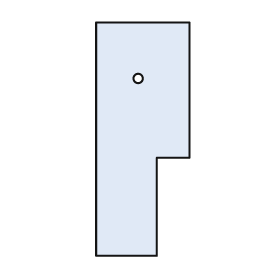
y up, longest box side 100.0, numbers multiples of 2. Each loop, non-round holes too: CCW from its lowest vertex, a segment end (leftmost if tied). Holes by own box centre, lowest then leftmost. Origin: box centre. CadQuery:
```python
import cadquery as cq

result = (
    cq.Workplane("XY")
    .moveTo(-20.0, -50.0)
    .lineTo(6.0, -50.0)
    .lineTo(6.0, -8.0)
    .lineTo(20.0, -8.0)
    .lineTo(20.0, 50.0)
    .lineTo(-20.0, 50.0)
    .close()
    .moveTo(-2.0, 26.0)
    .circle(2.0)
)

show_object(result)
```